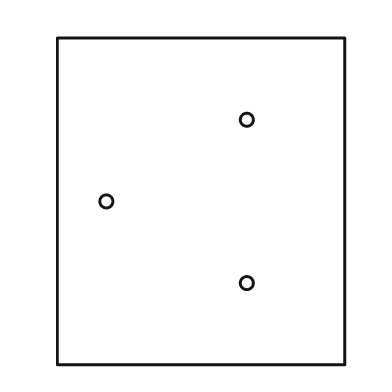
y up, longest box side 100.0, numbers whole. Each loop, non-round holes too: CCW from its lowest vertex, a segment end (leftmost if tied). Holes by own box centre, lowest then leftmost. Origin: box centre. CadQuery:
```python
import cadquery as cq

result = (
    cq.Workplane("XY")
    .moveTo(-44.0, -50.0)
    .lineTo(44.0, -50.0)
    .lineTo(44.0, 50.0)
    .lineTo(-44.0, 50.0)
    .close()
    .moveTo(14.0, -25.0)
    .circle(2.0)
    .moveTo(-29.0, 0.0)
    .circle(2.0)
    .moveTo(14.0, 25.0)
    .circle(2.0)
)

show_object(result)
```